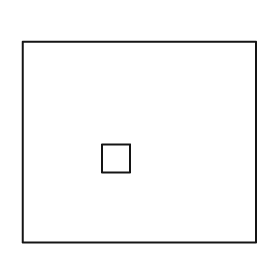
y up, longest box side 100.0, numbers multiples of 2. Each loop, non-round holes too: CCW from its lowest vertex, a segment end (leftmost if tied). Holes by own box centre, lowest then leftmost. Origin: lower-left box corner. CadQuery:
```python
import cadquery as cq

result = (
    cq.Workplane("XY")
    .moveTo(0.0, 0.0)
    .lineTo(100.0, 0.0)
    .lineTo(100.0, 86.0)
    .lineTo(0.0, 86.0)
    .close()
    .moveTo(34.0, 30.0)
    .lineTo(46.0, 30.0)
    .lineTo(46.0, 42.0)
    .lineTo(34.0, 42.0)
    .close()
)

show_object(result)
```